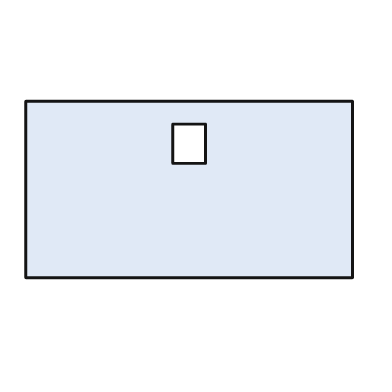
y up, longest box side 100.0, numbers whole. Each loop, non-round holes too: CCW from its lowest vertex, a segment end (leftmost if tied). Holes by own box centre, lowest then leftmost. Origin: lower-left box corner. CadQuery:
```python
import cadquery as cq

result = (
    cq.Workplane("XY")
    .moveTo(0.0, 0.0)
    .lineTo(100.0, 0.0)
    .lineTo(100.0, 54.0)
    .lineTo(0.0, 54.0)
    .close()
    .moveTo(45.0, 35.0)
    .lineTo(55.0, 35.0)
    .lineTo(55.0, 47.0)
    .lineTo(45.0, 47.0)
    .close()
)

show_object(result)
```